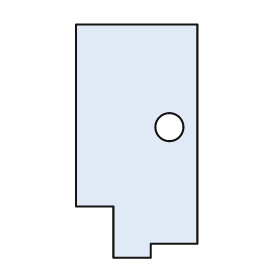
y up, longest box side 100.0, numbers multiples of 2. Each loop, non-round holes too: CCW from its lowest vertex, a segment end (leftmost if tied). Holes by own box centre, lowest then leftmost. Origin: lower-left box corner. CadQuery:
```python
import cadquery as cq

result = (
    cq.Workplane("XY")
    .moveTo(16.0, 0.0)
    .lineTo(32.0, 0.0)
    .lineTo(32.0, 6.0)
    .lineTo(52.0, 6.0)
    .lineTo(52.0, 100.0)
    .lineTo(0.0, 100.0)
    .lineTo(0.0, 22.0)
    .lineTo(16.0, 22.0)
    .close()
    .moveTo(40.0, 56.0)
    .circle(6.0)
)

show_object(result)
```